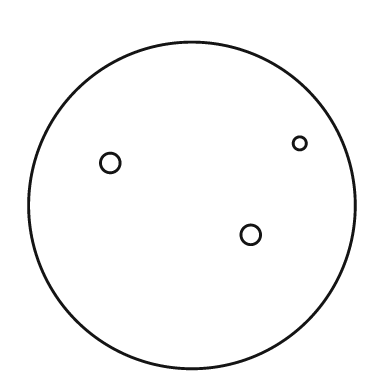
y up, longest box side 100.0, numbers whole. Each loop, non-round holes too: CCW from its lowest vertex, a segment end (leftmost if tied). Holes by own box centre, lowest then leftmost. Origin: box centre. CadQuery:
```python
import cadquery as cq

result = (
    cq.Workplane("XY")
    .moveTo(0.0, 0.0)
    .circle(50.0)
    .moveTo(18.0, -9.0)
    .circle(3.0)
    .moveTo(-25.0, 13.0)
    .circle(3.0)
    .moveTo(33.0, 19.0)
    .circle(2.0)
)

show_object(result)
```